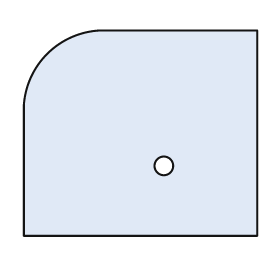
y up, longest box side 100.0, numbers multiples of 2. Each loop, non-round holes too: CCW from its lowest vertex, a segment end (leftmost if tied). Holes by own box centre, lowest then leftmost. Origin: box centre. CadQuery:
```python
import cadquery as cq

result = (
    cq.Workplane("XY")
    .moveTo(-50.0, -44.0)
    .lineTo(50.0, -44.0)
    .lineTo(50.0, 44.0)
    .lineTo(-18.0, 44.0)
    .threePointArc((-40.0, 34.0), (-50.0, 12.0))
    .close()
    .moveTo(10.0, -14.0)
    .circle(4.0)
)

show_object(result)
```